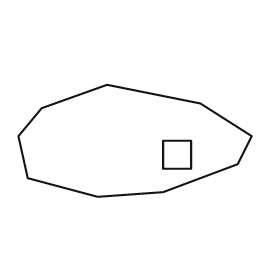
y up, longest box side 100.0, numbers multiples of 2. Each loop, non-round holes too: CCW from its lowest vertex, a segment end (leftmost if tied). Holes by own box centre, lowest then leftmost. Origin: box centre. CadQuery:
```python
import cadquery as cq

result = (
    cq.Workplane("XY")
    .moveTo(-16.0, -24.0)
    .lineTo(12.0, -22.0)
    .lineTo(44.0, -10.0)
    .lineTo(50.0, 2.0)
    .lineTo(28.0, 16.0)
    .lineTo(-12.0, 24.0)
    .lineTo(-40.0, 14.0)
    .lineTo(-50.0, 2.0)
    .lineTo(-46.0, -16.0)
    .close()
    .moveTo(12.0, -12.0)
    .lineTo(24.0, -12.0)
    .lineTo(24.0, 0.0)
    .lineTo(12.0, 0.0)
    .close()
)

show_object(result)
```